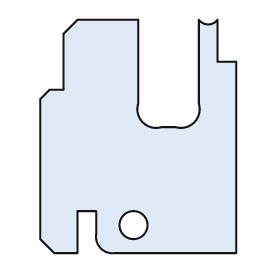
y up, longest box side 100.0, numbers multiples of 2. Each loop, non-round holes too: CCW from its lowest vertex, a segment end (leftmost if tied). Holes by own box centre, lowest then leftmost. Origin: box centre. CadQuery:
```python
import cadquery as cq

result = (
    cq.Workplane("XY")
    .moveTo(-36.0, -50.0)
    .lineTo(-26.0, -50.0)
    .lineTo(-26.0, -32.0)
    .lineTo(-18.0, -32.0)
    .lineTo(-18.0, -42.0)
    .threePointArc((-16.0, -48.0), (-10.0, -50.0))
    .lineTo(42.0, -50.0)
    .lineTo(42.0, 32.0)
    .lineTo(34.0, 32.0)
    .lineTo(34.0, 50.0)
    .threePointArc((30.0, 48.0), (26.0, 50.0))
    .lineTo(26.0, 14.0)
    .threePointArc((24.0, 6.0), (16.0, 4.0))
    .lineTo(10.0, 4.0)
    .threePointArc((2.0, 6.0), (0.0, 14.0))
    .lineTo(0.0, 50.0)
    .lineTo(-26.0, 50.0)
    .lineTo(-32.0, 44.0)
    .lineTo(-32.0, 20.0)
    .lineTo(-38.0, 20.0)
    .lineTo(-42.0, 16.0)
    .lineTo(-42.0, -44.0)
    .close()
    .moveTo(-2.0, -38.0)
    .circle(6.0)
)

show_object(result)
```